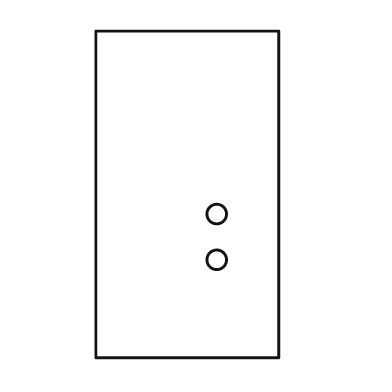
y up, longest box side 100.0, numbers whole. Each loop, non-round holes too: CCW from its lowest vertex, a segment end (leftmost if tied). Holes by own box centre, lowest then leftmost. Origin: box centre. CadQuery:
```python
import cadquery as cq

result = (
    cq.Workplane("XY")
    .moveTo(-28.0, -50.0)
    .lineTo(28.0, -50.0)
    .lineTo(28.0, 50.0)
    .lineTo(-28.0, 50.0)
    .close()
    .moveTo(9.0, -20.0)
    .circle(3.0)
    .moveTo(9.0, -6.0)
    .circle(3.0)
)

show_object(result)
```